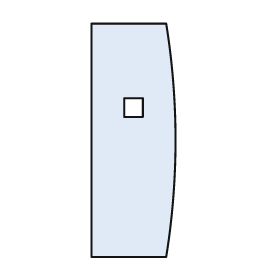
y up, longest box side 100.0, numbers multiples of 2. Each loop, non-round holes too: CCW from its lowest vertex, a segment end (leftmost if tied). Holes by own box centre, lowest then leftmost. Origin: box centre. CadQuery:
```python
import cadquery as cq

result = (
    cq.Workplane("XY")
    .moveTo(-18.0, -50.0)
    .lineTo(14.0, -50.0)
    .threePointArc((18.0, 0.0), (14.0, 50.0))
    .lineTo(-18.0, 50.0)
    .close()
    .moveTo(-4.0, 10.0)
    .lineTo(4.0, 10.0)
    .lineTo(4.0, 18.0)
    .lineTo(-4.0, 18.0)
    .close()
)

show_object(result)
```